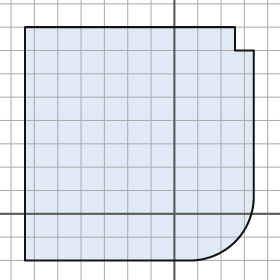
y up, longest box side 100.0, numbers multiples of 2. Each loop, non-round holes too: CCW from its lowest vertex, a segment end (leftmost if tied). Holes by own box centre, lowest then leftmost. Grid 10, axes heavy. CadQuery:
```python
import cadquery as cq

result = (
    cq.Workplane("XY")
    .moveTo(-64.0, -20.0)
    .lineTo(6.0, -20.0)
    .threePointArc((26.0, -12.0), (34.0, 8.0))
    .lineTo(34.0, 70.0)
    .lineTo(26.0, 70.0)
    .lineTo(26.0, 80.0)
    .lineTo(-64.0, 80.0)
    .close()
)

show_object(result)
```